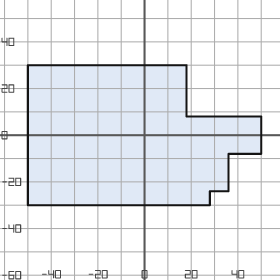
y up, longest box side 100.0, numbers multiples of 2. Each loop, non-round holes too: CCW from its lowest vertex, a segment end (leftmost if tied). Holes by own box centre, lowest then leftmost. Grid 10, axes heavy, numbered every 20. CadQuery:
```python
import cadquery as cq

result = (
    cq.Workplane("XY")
    .moveTo(-50.0, -30.0)
    .lineTo(28.0, -30.0)
    .lineTo(28.0, -24.0)
    .lineTo(36.0, -24.0)
    .lineTo(36.0, -8.0)
    .lineTo(50.0, -8.0)
    .lineTo(50.0, 8.0)
    .lineTo(18.0, 8.0)
    .lineTo(18.0, 30.0)
    .lineTo(-50.0, 30.0)
    .close()
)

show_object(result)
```